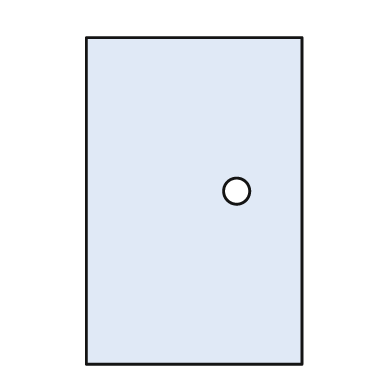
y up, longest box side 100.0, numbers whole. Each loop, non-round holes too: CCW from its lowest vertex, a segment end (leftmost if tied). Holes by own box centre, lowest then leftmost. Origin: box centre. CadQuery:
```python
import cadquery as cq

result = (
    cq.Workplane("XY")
    .moveTo(-33.0, -50.0)
    .lineTo(33.0, -50.0)
    .lineTo(33.0, 50.0)
    .lineTo(-33.0, 50.0)
    .close()
    .moveTo(13.0, 3.0)
    .circle(4.0)
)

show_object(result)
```